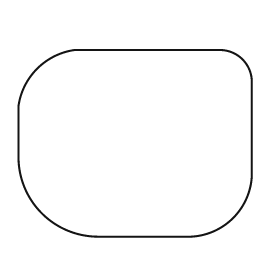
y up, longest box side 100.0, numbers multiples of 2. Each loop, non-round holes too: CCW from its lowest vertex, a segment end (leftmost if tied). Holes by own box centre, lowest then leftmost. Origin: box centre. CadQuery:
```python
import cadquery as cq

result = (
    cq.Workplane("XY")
    .moveTo(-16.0, -40.0)
    .lineTo(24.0, -40.0)
    .threePointArc((42.0, -32.0), (50.0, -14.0))
    .lineTo(50.0, 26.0)
    .threePointArc((46.0, 36.0), (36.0, 40.0))
    .lineTo(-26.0, 40.0)
    .threePointArc((-42.0, 32.0), (-50.0, 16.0))
    .lineTo(-50.0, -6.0)
    .threePointArc((-40.0, -30.0), (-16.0, -40.0))
    .close()
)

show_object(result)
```